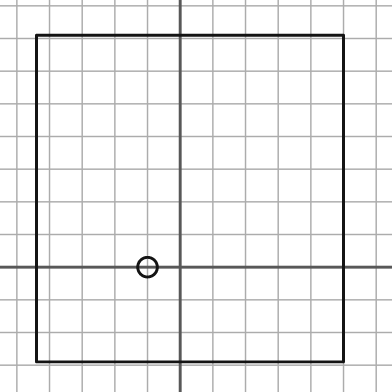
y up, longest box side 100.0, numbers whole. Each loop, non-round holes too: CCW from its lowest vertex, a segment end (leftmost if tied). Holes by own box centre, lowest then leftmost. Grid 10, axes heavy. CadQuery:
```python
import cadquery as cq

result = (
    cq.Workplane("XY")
    .moveTo(-44.0, -29.0)
    .lineTo(50.0, -29.0)
    .lineTo(50.0, 71.0)
    .lineTo(-44.0, 71.0)
    .close()
    .moveTo(-10.0, 0.0)
    .circle(3.0)
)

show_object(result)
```